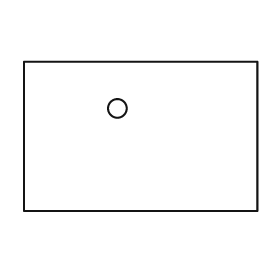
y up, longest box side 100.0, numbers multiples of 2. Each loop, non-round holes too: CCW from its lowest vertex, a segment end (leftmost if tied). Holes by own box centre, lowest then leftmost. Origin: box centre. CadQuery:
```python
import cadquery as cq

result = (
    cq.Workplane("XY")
    .moveTo(-50.0, -32.0)
    .lineTo(50.0, -32.0)
    .lineTo(50.0, 32.0)
    .lineTo(-50.0, 32.0)
    .close()
    .moveTo(-10.0, 12.0)
    .circle(4.0)
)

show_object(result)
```